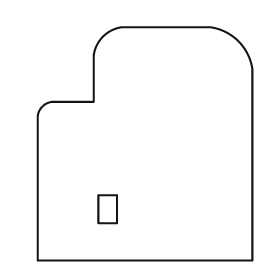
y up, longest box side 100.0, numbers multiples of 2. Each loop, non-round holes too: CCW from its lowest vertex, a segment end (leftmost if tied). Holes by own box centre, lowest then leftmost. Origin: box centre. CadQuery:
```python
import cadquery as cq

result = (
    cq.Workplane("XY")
    .moveTo(-46.0, -50.0)
    .lineTo(46.0, -50.0)
    .lineTo(46.0, 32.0)
    .threePointArc((40.0, 44.0), (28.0, 50.0))
    .lineTo(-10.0, 50.0)
    .threePointArc((-18.0, 46.0), (-22.0, 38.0))
    .lineTo(-22.0, 18.0)
    .lineTo(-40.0, 18.0)
    .threePointArc((-44.0, 16.0), (-46.0, 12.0))
    .close()
    .moveTo(-20.0, -34.0)
    .lineTo(-12.0, -34.0)
    .lineTo(-12.0, -22.0)
    .lineTo(-20.0, -22.0)
    .close()
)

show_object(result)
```